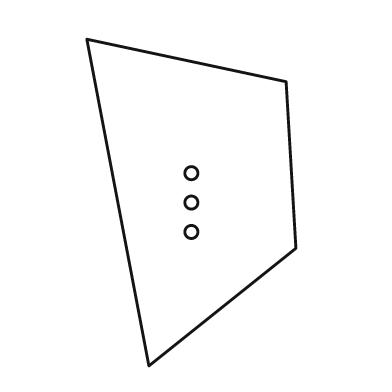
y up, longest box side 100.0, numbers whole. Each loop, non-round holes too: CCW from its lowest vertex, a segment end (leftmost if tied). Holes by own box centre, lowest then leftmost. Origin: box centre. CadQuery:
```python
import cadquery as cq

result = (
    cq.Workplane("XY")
    .moveTo(-13.0, -50.0)
    .lineTo(32.0, -14.0)
    .lineTo(29.0, 37.0)
    .lineTo(-32.0, 50.0)
    .close()
    .moveTo(0.0, -9.0)
    .circle(2.0)
    .moveTo(0.0, 0.0)
    .circle(2.0)
    .moveTo(0.0, 9.0)
    .circle(2.0)
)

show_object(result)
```